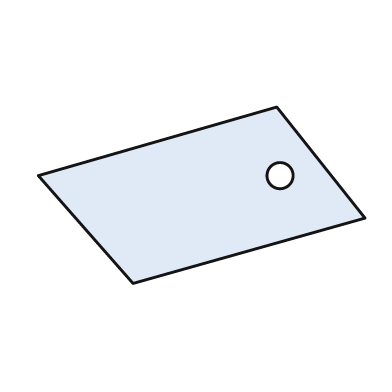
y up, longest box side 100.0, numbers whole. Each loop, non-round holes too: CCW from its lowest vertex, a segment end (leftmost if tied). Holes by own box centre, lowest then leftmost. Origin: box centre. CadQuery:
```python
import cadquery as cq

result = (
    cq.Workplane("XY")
    .moveTo(-21.0, -27.0)
    .lineTo(50.0, -7.0)
    .lineTo(23.0, 27.0)
    .lineTo(-50.0, 6.0)
    .close()
    .moveTo(24.0, 6.0)
    .circle(4.0)
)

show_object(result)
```